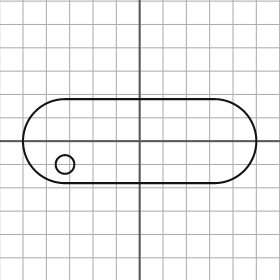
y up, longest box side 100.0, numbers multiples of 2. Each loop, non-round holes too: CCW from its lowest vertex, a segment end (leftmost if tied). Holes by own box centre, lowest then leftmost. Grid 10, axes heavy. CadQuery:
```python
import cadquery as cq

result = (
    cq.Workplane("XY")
    .moveTo(-32.0, -18.0)
    .lineTo(32.0, -18.0)
    .threePointArc((50.0, 0.0), (32.0, 18.0))
    .lineTo(-32.0, 18.0)
    .threePointArc((-50.0, 0.0), (-32.0, -18.0))
    .close()
    .moveTo(-32.0, -10.0)
    .circle(4.0)
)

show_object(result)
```